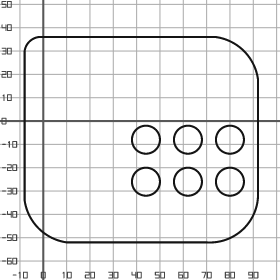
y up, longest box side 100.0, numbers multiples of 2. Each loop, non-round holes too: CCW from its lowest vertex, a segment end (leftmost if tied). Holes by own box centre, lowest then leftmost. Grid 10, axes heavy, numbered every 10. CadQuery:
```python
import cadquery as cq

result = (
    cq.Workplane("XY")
    .moveTo(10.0, -52.0)
    .lineTo(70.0, -52.0)
    .threePointArc((86.0, -46.0), (92.0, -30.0))
    .lineTo(92.0, 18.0)
    .threePointArc((86.0, 30.0), (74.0, 36.0))
    .lineTo(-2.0, 36.0)
    .threePointArc((-6.0, 34.0), (-8.0, 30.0))
    .lineTo(-8.0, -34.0)
    .threePointArc((-2.0, -46.0), (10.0, -52.0))
    .close()
    .moveTo(44.0, -26.0)
    .circle(6.0)
    .moveTo(62.0, -26.0)
    .circle(6.0)
    .moveTo(80.0, -26.0)
    .circle(6.0)
    .moveTo(44.0, -8.0)
    .circle(6.0)
    .moveTo(62.0, -8.0)
    .circle(6.0)
    .moveTo(80.0, -8.0)
    .circle(6.0)
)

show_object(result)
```